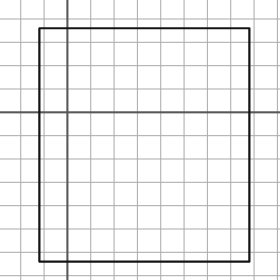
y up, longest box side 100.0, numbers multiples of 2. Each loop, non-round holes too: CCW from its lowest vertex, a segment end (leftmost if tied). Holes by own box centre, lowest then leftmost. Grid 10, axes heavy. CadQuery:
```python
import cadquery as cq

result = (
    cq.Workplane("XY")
    .moveTo(-12.0, -64.0)
    .lineTo(78.0, -64.0)
    .lineTo(78.0, 36.0)
    .lineTo(-12.0, 36.0)
    .close()
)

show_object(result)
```